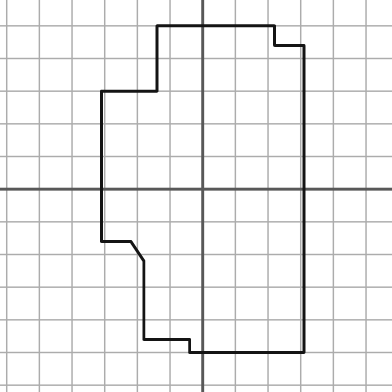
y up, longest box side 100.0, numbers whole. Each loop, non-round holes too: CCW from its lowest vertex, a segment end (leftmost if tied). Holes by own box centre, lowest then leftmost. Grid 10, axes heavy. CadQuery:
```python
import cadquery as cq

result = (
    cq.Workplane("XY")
    .moveTo(-4.0, -50.0)
    .lineTo(31.0, -50.0)
    .lineTo(31.0, 44.0)
    .lineTo(22.0, 44.0)
    .lineTo(22.0, 50.0)
    .lineTo(-14.0, 50.0)
    .lineTo(-14.0, 30.0)
    .lineTo(-31.0, 30.0)
    .lineTo(-31.0, -16.0)
    .lineTo(-22.0, -16.0)
    .lineTo(-18.0, -22.0)
    .lineTo(-18.0, -46.0)
    .lineTo(-4.0, -46.0)
    .close()
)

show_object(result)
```